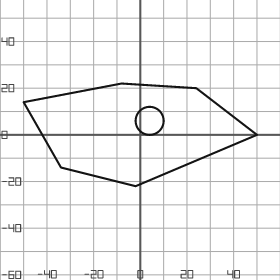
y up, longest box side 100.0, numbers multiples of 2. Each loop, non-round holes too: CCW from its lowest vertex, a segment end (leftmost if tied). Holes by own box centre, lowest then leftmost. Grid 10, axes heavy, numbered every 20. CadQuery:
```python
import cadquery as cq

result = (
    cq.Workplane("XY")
    .moveTo(-2.0, -22.0)
    .lineTo(50.0, 0.0)
    .lineTo(24.0, 20.0)
    .lineTo(-8.0, 22.0)
    .lineTo(-50.0, 14.0)
    .lineTo(-34.0, -14.0)
    .close()
    .moveTo(4.0, 6.0)
    .circle(6.0)
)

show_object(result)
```